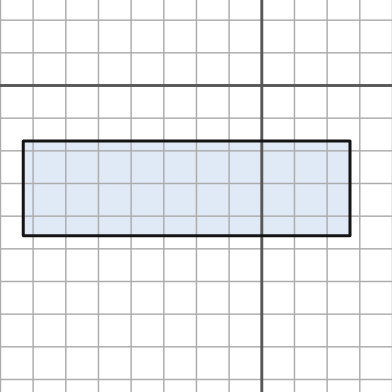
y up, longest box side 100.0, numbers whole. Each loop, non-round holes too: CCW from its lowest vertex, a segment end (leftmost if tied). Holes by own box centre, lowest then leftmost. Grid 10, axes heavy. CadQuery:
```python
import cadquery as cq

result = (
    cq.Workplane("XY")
    .moveTo(-73.0, -46.0)
    .lineTo(27.0, -46.0)
    .lineTo(27.0, -17.0)
    .lineTo(-73.0, -17.0)
    .close()
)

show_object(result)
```